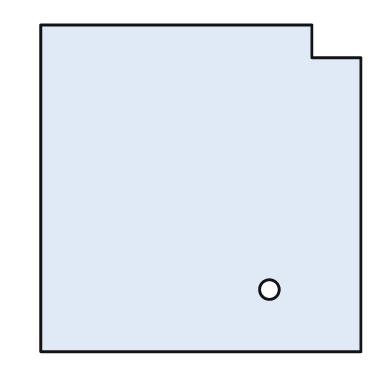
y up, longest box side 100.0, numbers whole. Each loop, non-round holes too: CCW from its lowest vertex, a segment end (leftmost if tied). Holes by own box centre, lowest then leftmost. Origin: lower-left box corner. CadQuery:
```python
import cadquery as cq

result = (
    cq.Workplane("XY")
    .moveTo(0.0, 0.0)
    .lineTo(98.0, 0.0)
    .lineTo(98.0, 90.0)
    .lineTo(83.0, 90.0)
    .lineTo(83.0, 100.0)
    .lineTo(0.0, 100.0)
    .close()
    .moveTo(70.0, 19.0)
    .circle(3.0)
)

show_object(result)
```